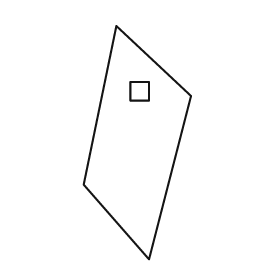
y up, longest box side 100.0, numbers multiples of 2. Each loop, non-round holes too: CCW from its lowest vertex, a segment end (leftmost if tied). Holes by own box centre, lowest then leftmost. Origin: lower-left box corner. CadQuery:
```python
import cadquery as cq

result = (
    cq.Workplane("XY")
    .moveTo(28.0, 0.0)
    .lineTo(46.0, 70.0)
    .lineTo(14.0, 100.0)
    .lineTo(0.0, 32.0)
    .close()
    .moveTo(20.0, 68.0)
    .lineTo(28.0, 68.0)
    .lineTo(28.0, 76.0)
    .lineTo(20.0, 76.0)
    .close()
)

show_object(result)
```